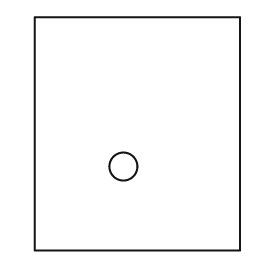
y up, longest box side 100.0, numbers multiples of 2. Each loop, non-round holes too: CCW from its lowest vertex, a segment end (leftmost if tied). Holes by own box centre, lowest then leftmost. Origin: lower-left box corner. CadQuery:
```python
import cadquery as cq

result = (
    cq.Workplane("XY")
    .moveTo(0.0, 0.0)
    .lineTo(88.0, 0.0)
    .lineTo(88.0, 100.0)
    .lineTo(0.0, 100.0)
    .close()
    .moveTo(38.0, 36.0)
    .circle(6.0)
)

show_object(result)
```